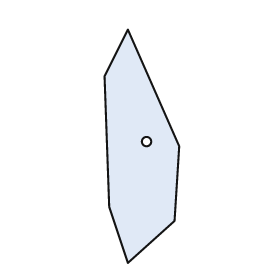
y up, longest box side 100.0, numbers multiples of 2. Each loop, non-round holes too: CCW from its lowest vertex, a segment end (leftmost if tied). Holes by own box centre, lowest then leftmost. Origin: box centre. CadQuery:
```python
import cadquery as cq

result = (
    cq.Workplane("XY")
    .moveTo(-6.0, -50.0)
    .lineTo(14.0, -32.0)
    .lineTo(16.0, 0.0)
    .lineTo(-6.0, 50.0)
    .lineTo(-16.0, 30.0)
    .lineTo(-14.0, -26.0)
    .close()
    .moveTo(2.0, 2.0)
    .circle(2.0)
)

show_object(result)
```